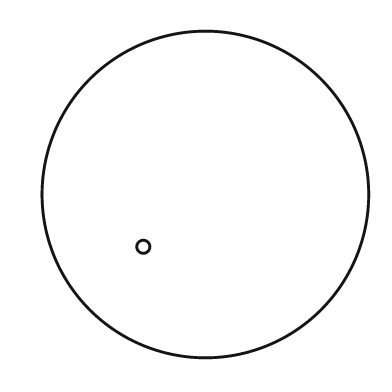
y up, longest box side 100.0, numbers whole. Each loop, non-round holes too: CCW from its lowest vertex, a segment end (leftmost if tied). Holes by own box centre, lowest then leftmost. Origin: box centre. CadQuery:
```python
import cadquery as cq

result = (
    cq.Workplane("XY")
    .moveTo(0.0, 0.0)
    .circle(50.0)
    .moveTo(-19.0, -16.0)
    .circle(2.0)
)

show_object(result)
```